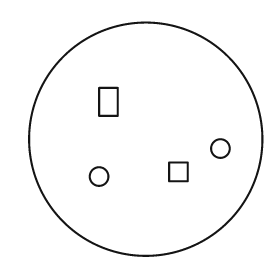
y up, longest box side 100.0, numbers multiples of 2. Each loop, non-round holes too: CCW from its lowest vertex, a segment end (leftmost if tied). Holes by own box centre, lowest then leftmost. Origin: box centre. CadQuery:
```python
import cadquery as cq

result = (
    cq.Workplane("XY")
    .moveTo(0.0, 0.0)
    .circle(50.0)
    .moveTo(-20.0, -16.0)
    .circle(4.0)
    .moveTo(10.0, -18.0)
    .lineTo(18.0, -18.0)
    .lineTo(18.0, -10.0)
    .lineTo(10.0, -10.0)
    .close()
    .moveTo(32.0, -4.0)
    .circle(4.0)
    .moveTo(-20.0, 10.0)
    .lineTo(-12.0, 10.0)
    .lineTo(-12.0, 22.0)
    .lineTo(-20.0, 22.0)
    .close()
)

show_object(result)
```